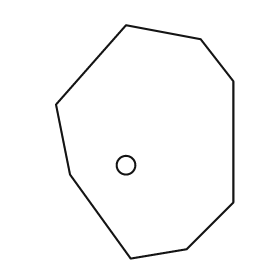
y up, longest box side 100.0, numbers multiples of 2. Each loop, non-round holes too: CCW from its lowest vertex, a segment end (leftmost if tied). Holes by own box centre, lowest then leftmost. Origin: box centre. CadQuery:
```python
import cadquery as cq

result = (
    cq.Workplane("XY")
    .moveTo(-6.0, -50.0)
    .lineTo(18.0, -46.0)
    .lineTo(38.0, -26.0)
    .lineTo(38.0, 26.0)
    .lineTo(24.0, 44.0)
    .lineTo(-8.0, 50.0)
    .lineTo(-38.0, 16.0)
    .lineTo(-32.0, -14.0)
    .close()
    .moveTo(-8.0, -10.0)
    .circle(4.0)
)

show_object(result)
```